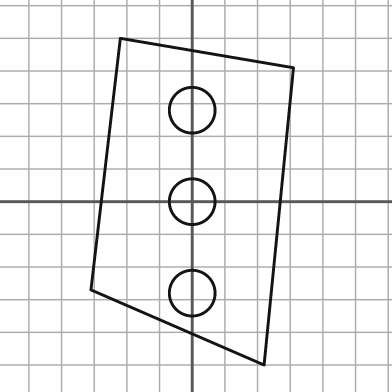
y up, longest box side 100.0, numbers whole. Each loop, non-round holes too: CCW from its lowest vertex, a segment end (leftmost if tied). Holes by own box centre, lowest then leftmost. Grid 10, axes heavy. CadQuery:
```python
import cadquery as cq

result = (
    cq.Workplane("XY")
    .moveTo(22.0, -50.0)
    .lineTo(31.0, 41.0)
    .lineTo(-22.0, 50.0)
    .lineTo(-31.0, -27.0)
    .close()
    .moveTo(0.0, -28.0)
    .circle(7.0)
    .moveTo(0.0, 0.0)
    .circle(7.0)
    .moveTo(0.0, 28.0)
    .circle(7.0)
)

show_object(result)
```